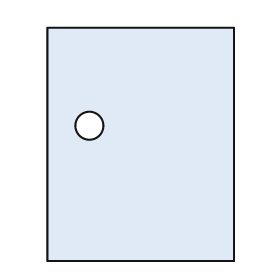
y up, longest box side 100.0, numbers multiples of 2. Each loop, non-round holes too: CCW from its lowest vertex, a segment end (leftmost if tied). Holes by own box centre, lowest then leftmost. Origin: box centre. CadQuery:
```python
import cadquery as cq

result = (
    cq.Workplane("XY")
    .moveTo(-40.0, -50.0)
    .lineTo(40.0, -50.0)
    .lineTo(40.0, 50.0)
    .lineTo(-40.0, 50.0)
    .close()
    .moveTo(-22.0, 8.0)
    .circle(6.0)
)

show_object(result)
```